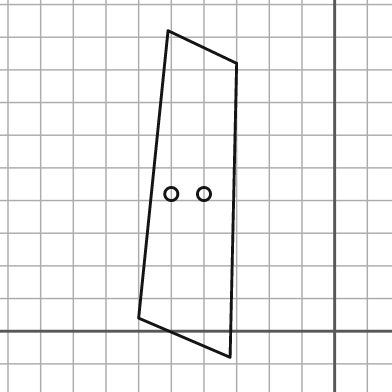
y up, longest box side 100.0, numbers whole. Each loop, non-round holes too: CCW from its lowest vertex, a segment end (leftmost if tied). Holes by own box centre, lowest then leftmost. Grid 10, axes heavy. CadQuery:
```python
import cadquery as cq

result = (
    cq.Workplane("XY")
    .moveTo(-32.0, -8.0)
    .lineTo(-30.0, 82.0)
    .lineTo(-51.0, 92.0)
    .lineTo(-60.0, 4.0)
    .close()
    .moveTo(-50.0, 42.0)
    .circle(2.0)
    .moveTo(-40.0, 42.0)
    .circle(2.0)
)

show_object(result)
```